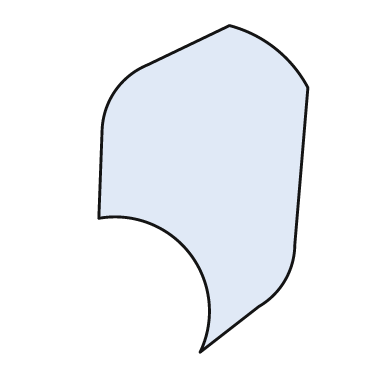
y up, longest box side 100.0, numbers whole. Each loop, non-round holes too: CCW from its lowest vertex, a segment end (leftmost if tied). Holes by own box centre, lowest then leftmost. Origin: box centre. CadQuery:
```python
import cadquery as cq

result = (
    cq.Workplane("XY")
    .moveTo(-1.0, -50.0)
    .lineTo(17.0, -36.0)
    .threePointArc((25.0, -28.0), (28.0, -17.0))
    .lineTo(32.0, 31.0)
    .threePointArc((22.0, 43.0), (8.0, 50.0))
    .lineTo(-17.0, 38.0)
    .threePointArc((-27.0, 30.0), (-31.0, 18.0))
    .lineTo(-32.0, -9.0)
    .threePointArc((-4.0, -20.0), (-1.0, -50.0))
    .close()
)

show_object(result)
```